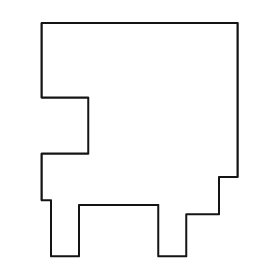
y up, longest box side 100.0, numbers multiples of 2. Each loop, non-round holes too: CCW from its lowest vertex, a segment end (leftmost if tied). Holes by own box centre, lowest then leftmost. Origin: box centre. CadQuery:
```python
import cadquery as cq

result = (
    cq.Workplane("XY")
    .moveTo(-38.0, -50.0)
    .lineTo(-26.0, -50.0)
    .lineTo(-26.0, -28.0)
    .lineTo(8.0, -28.0)
    .lineTo(8.0, -50.0)
    .lineTo(20.0, -50.0)
    .lineTo(20.0, -32.0)
    .lineTo(34.0, -32.0)
    .lineTo(34.0, -16.0)
    .lineTo(42.0, -16.0)
    .lineTo(42.0, 50.0)
    .lineTo(-42.0, 50.0)
    .lineTo(-42.0, 18.0)
    .lineTo(-22.0, 18.0)
    .lineTo(-22.0, -6.0)
    .lineTo(-42.0, -6.0)
    .lineTo(-42.0, -26.0)
    .lineTo(-38.0, -26.0)
    .close()
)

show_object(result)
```